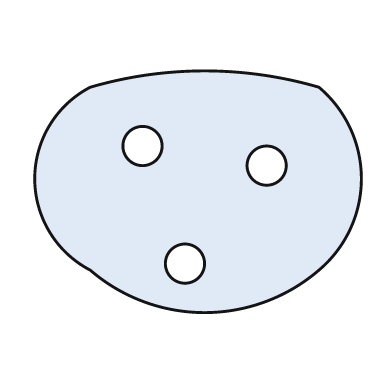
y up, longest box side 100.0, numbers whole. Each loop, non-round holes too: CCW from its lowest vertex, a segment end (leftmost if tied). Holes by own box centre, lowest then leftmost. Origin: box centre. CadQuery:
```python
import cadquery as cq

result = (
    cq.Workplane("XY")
    .moveTo(-33.0, -24.0)
    .threePointArc((2.0, -37.0), (37.0, -24.0))
    .threePointArc((50.0, 4.0), (37.0, 32.0))
    .threePointArc((2.0, 37.0), (-33.0, 32.0))
    .threePointArc((-50.0, 4.0), (-33.0, -24.0))
    .close()
    .moveTo(-4.0, -22.0)
    .circle(6.0)
    .moveTo(21.0, 8.0)
    .circle(6.0)
    .moveTo(-17.0, 14.0)
    .circle(6.0)
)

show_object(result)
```